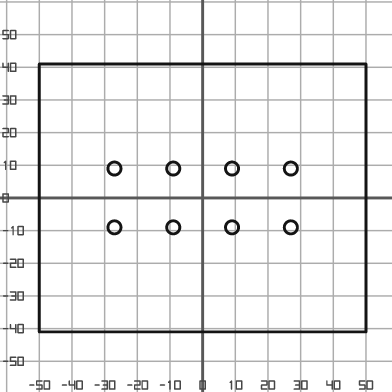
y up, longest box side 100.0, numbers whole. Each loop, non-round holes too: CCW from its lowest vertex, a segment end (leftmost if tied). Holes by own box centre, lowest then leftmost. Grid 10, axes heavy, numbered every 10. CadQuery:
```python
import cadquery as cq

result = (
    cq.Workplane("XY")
    .moveTo(-50.0, -41.0)
    .lineTo(50.0, -41.0)
    .lineTo(50.0, 41.0)
    .lineTo(-50.0, 41.0)
    .close()
    .moveTo(-27.0, -9.0)
    .circle(2.0)
    .moveTo(-9.0, -9.0)
    .circle(2.0)
    .moveTo(9.0, -9.0)
    .circle(2.0)
    .moveTo(27.0, -9.0)
    .circle(2.0)
    .moveTo(-27.0, 9.0)
    .circle(2.0)
    .moveTo(-9.0, 9.0)
    .circle(2.0)
    .moveTo(9.0, 9.0)
    .circle(2.0)
    .moveTo(27.0, 9.0)
    .circle(2.0)
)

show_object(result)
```